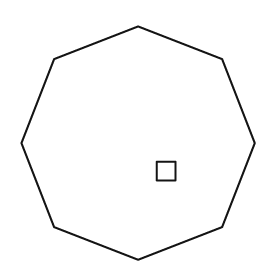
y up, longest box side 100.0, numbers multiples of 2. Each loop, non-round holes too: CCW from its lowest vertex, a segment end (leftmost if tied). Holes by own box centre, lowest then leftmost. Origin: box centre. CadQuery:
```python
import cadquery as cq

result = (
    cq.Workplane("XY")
    .moveTo(0.0, -50.0)
    .lineTo(36.0, -36.0)
    .lineTo(50.0, 0.0)
    .lineTo(36.0, 36.0)
    .lineTo(0.0, 50.0)
    .lineTo(-36.0, 36.0)
    .lineTo(-50.0, 0.0)
    .lineTo(-36.0, -36.0)
    .close()
    .moveTo(8.0, -16.0)
    .lineTo(16.0, -16.0)
    .lineTo(16.0, -8.0)
    .lineTo(8.0, -8.0)
    .close()
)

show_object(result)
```